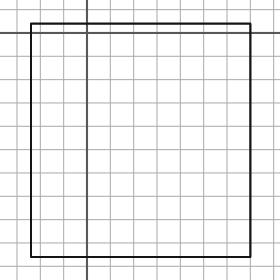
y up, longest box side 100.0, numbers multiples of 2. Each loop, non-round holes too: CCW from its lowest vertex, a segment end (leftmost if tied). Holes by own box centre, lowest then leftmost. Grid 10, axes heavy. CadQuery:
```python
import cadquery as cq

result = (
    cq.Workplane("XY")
    .moveTo(-24.0, -96.0)
    .lineTo(70.0, -96.0)
    .lineTo(70.0, 4.0)
    .lineTo(-24.0, 4.0)
    .close()
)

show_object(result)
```